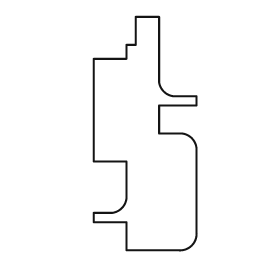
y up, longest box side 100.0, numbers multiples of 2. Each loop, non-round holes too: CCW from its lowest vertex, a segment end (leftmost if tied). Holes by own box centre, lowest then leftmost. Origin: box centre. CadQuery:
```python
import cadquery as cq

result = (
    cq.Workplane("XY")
    .moveTo(-8.0, -50.0)
    .lineTo(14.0, -50.0)
    .threePointArc((20.0, -48.0), (22.0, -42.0))
    .lineTo(22.0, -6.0)
    .threePointArc((20.0, -2.0), (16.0, 0.0))
    .lineTo(6.0, 0.0)
    .lineTo(6.0, 12.0)
    .lineTo(22.0, 12.0)
    .lineTo(22.0, 16.0)
    .lineTo(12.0, 16.0)
    .threePointArc((8.0, 18.0), (6.0, 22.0))
    .lineTo(6.0, 50.0)
    .lineTo(-4.0, 50.0)
    .lineTo(-4.0, 38.0)
    .lineTo(-8.0, 38.0)
    .lineTo(-8.0, 32.0)
    .lineTo(-22.0, 32.0)
    .lineTo(-22.0, -12.0)
    .lineTo(-8.0, -12.0)
    .lineTo(-8.0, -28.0)
    .threePointArc((-10.0, -32.0), (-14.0, -34.0))
    .lineTo(-22.0, -34.0)
    .lineTo(-22.0, -38.0)
    .lineTo(-8.0, -38.0)
    .close()
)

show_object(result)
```